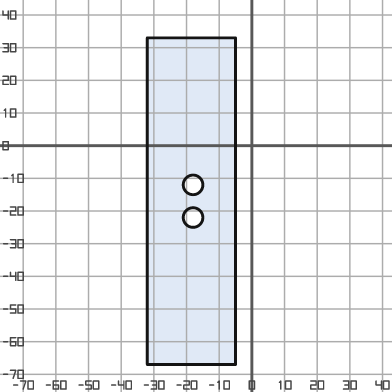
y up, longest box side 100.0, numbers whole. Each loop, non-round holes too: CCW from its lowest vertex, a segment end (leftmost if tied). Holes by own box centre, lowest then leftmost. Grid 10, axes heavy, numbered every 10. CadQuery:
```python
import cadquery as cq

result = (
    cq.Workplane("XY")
    .moveTo(-32.0, -67.0)
    .lineTo(-5.0, -67.0)
    .lineTo(-5.0, 33.0)
    .lineTo(-32.0, 33.0)
    .close()
    .moveTo(-18.0, -22.0)
    .circle(3.0)
    .moveTo(-18.0, -12.0)
    .circle(3.0)
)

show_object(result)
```